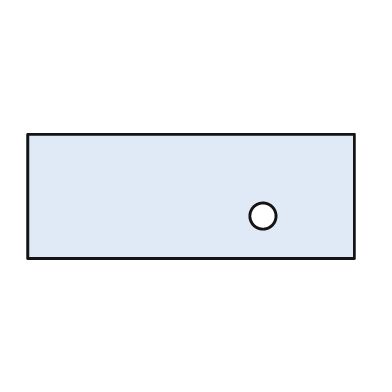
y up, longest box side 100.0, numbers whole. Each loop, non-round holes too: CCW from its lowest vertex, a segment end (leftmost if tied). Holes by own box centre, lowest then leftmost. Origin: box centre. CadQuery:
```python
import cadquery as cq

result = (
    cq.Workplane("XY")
    .moveTo(-50.0, -19.0)
    .lineTo(50.0, -19.0)
    .lineTo(50.0, 19.0)
    .lineTo(-50.0, 19.0)
    .close()
    .moveTo(22.0, -6.0)
    .circle(4.0)
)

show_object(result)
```